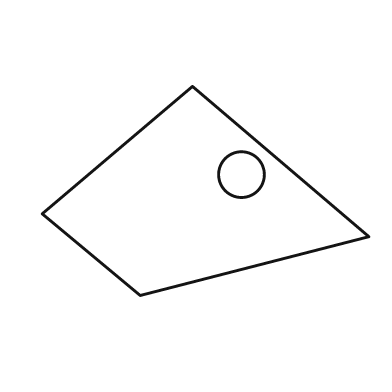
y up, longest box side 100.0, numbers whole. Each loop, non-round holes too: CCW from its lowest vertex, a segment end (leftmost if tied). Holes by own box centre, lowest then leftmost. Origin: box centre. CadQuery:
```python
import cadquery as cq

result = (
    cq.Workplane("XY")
    .moveTo(-20.0, -32.0)
    .lineTo(50.0, -14.0)
    .lineTo(-4.0, 32.0)
    .lineTo(-50.0, -7.0)
    .close()
    .moveTo(11.0, 5.0)
    .circle(7.0)
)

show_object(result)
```